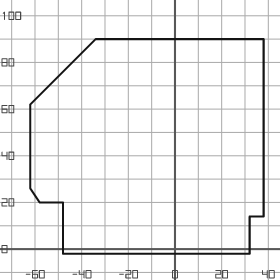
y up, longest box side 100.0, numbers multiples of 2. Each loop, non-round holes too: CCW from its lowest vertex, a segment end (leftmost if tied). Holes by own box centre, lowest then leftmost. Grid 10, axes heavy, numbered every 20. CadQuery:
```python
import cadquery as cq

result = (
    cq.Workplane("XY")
    .moveTo(-48.0, -2.0)
    .lineTo(32.0, -2.0)
    .lineTo(32.0, 14.0)
    .lineTo(38.0, 14.0)
    .lineTo(38.0, 90.0)
    .lineTo(-34.0, 90.0)
    .lineTo(-62.0, 62.0)
    .lineTo(-62.0, 26.0)
    .lineTo(-58.0, 20.0)
    .lineTo(-48.0, 20.0)
    .close()
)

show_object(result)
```